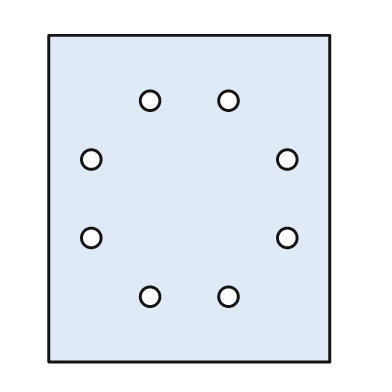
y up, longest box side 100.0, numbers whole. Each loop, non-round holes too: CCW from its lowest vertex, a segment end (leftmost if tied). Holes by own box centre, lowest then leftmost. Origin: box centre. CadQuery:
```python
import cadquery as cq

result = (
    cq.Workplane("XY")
    .moveTo(-43.0, -50.0)
    .lineTo(43.0, -50.0)
    .lineTo(43.0, 50.0)
    .lineTo(-43.0, 50.0)
    .close()
    .moveTo(-12.0, -30.0)
    .circle(3.0)
    .moveTo(12.0, -30.0)
    .circle(3.0)
    .moveTo(-30.0, -12.0)
    .circle(3.0)
    .moveTo(30.0, -12.0)
    .circle(3.0)
    .moveTo(-30.0, 12.0)
    .circle(3.0)
    .moveTo(30.0, 12.0)
    .circle(3.0)
    .moveTo(-12.0, 30.0)
    .circle(3.0)
    .moveTo(12.0, 30.0)
    .circle(3.0)
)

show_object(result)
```